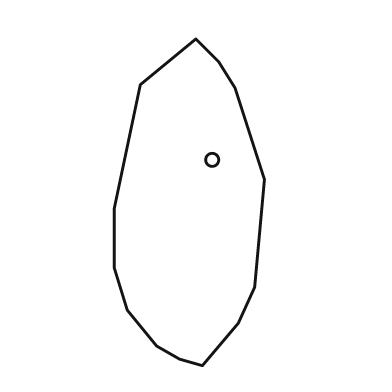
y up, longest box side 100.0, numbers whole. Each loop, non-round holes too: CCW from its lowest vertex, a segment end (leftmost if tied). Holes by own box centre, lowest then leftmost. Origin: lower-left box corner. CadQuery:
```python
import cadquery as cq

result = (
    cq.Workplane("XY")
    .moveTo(27.0, 0.0)
    .lineTo(38.0, 13.0)
    .lineTo(43.0, 24.0)
    .lineTo(46.0, 57.0)
    .lineTo(37.0, 85.0)
    .lineTo(32.0, 93.0)
    .lineTo(25.0, 100.0)
    .lineTo(8.0, 86.0)
    .lineTo(0.0, 48.0)
    .lineTo(0.0, 30.0)
    .lineTo(4.0, 17.0)
    .lineTo(13.0, 6.0)
    .lineTo(20.0, 2.0)
    .close()
    .moveTo(30.0, 63.0)
    .circle(2.0)
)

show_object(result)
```